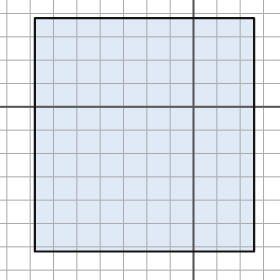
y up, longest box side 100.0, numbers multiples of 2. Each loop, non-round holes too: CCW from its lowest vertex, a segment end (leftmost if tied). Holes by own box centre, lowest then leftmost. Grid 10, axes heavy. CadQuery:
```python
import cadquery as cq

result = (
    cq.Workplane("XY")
    .moveTo(-68.0, -62.0)
    .lineTo(26.0, -62.0)
    .lineTo(26.0, 38.0)
    .lineTo(-68.0, 38.0)
    .close()
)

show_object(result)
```